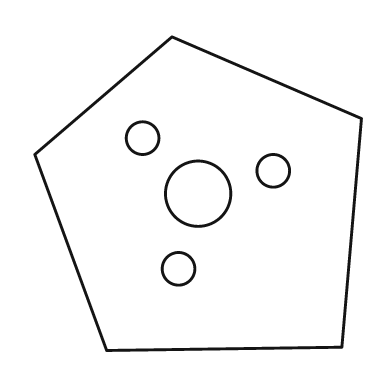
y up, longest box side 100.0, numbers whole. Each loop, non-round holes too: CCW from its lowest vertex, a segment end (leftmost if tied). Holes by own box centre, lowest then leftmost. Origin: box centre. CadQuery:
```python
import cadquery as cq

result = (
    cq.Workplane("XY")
    .moveTo(-28.0, -48.0)
    .lineTo(44.0, -47.0)
    .lineTo(50.0, 23.0)
    .lineTo(-8.0, 48.0)
    .lineTo(-50.0, 12.0)
    .close()
    .moveTo(-6.0, -23.0)
    .circle(5.0)
    .moveTo(0.0, 0.0)
    .circle(10.0)
    .moveTo(23.0, 7.0)
    .circle(5.0)
    .moveTo(-17.0, 17.0)
    .circle(5.0)
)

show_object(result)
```